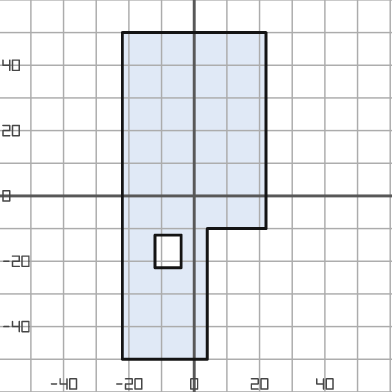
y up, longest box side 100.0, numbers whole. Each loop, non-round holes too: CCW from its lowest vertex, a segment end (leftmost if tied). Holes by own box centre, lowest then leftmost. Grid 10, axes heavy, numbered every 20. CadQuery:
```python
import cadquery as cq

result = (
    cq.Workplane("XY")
    .moveTo(-22.0, -50.0)
    .lineTo(4.0, -50.0)
    .lineTo(4.0, -10.0)
    .lineTo(22.0, -10.0)
    .lineTo(22.0, 50.0)
    .lineTo(-22.0, 50.0)
    .close()
    .moveTo(-12.0, -22.0)
    .lineTo(-4.0, -22.0)
    .lineTo(-4.0, -12.0)
    .lineTo(-12.0, -12.0)
    .close()
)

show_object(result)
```